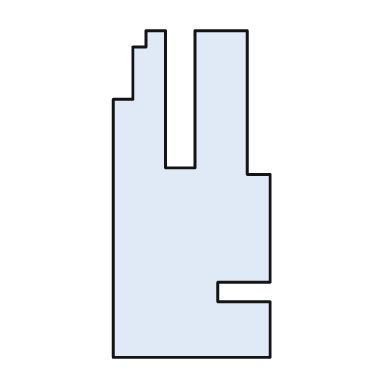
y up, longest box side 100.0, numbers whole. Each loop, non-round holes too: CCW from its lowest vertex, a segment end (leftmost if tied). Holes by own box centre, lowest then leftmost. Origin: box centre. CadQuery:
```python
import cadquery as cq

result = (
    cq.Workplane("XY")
    .moveTo(-24.0, -50.0)
    .lineTo(24.0, -50.0)
    .lineTo(24.0, -33.0)
    .lineTo(8.0, -33.0)
    .lineTo(8.0, -27.0)
    .lineTo(24.0, -27.0)
    .lineTo(24.0, 6.0)
    .lineTo(17.0, 6.0)
    .lineTo(17.0, 50.0)
    .lineTo(1.0, 50.0)
    .lineTo(1.0, 8.0)
    .lineTo(-8.0, 8.0)
    .lineTo(-8.0, 50.0)
    .lineTo(-14.0, 50.0)
    .lineTo(-14.0, 45.0)
    .lineTo(-18.0, 45.0)
    .lineTo(-18.0, 29.0)
    .lineTo(-24.0, 29.0)
    .close()
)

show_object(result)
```